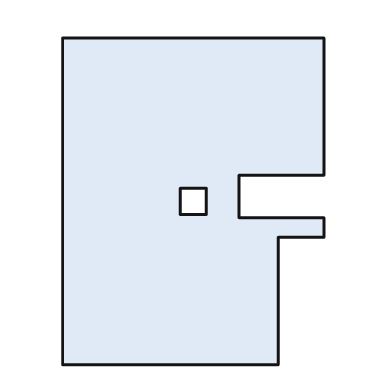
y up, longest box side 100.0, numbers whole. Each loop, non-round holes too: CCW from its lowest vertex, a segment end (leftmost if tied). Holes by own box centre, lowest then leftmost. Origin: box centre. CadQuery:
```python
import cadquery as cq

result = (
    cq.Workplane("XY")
    .moveTo(-40.0, -50.0)
    .lineTo(26.0, -50.0)
    .lineTo(26.0, -11.0)
    .lineTo(40.0, -11.0)
    .lineTo(40.0, -5.0)
    .lineTo(14.0, -5.0)
    .lineTo(14.0, 8.0)
    .lineTo(40.0, 8.0)
    .lineTo(40.0, 50.0)
    .lineTo(-40.0, 50.0)
    .close()
    .moveTo(-4.0, -4.0)
    .lineTo(4.0, -4.0)
    .lineTo(4.0, 4.0)
    .lineTo(-4.0, 4.0)
    .close()
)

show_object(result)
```